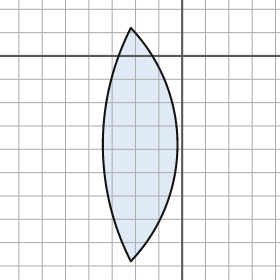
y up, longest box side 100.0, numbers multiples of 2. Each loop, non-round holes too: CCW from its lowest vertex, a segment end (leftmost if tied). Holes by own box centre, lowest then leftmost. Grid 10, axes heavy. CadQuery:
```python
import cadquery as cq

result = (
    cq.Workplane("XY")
    .moveTo(-22.0, -88.0)
    .threePointArc((-2.0, -38.0), (-22.0, 12.0))
    .threePointArc((-34.0, -38.0), (-22.0, -88.0))
    .close()
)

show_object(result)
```